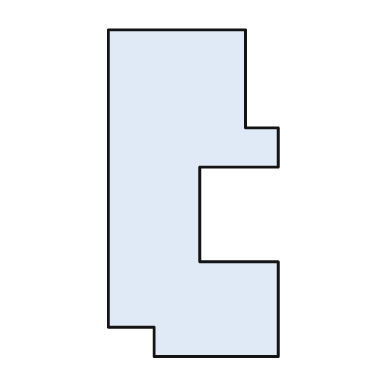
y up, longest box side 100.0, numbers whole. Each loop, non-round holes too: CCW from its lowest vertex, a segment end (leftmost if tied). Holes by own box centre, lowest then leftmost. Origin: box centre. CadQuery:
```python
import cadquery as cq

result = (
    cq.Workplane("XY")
    .moveTo(-12.0, -50.0)
    .lineTo(26.0, -50.0)
    .lineTo(26.0, -21.0)
    .lineTo(2.0, -21.0)
    .lineTo(2.0, 8.0)
    .lineTo(26.0, 8.0)
    .lineTo(26.0, 20.0)
    .lineTo(16.0, 20.0)
    .lineTo(16.0, 50.0)
    .lineTo(-26.0, 50.0)
    .lineTo(-26.0, -41.0)
    .lineTo(-12.0, -41.0)
    .close()
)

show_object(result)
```